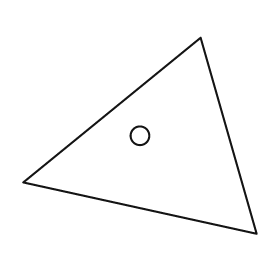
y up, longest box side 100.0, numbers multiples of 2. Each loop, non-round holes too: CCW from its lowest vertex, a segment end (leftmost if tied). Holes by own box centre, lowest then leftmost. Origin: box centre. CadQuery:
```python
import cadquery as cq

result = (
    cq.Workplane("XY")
    .moveTo(50.0, -42.0)
    .lineTo(26.0, 42.0)
    .lineTo(-50.0, -20.0)
    .close()
    .moveTo(0.0, 0.0)
    .circle(4.0)
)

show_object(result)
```